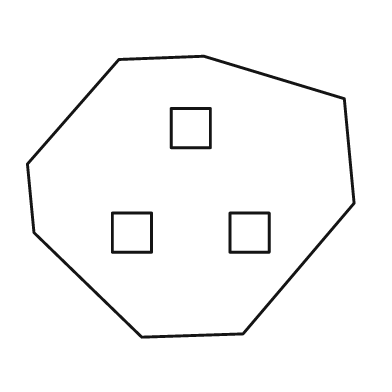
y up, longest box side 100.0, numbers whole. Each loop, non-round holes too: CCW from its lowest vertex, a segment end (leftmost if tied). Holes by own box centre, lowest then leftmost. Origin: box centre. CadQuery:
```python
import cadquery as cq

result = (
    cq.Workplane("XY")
    .moveTo(-15.0, -43.0)
    .lineTo(16.0, -42.0)
    .lineTo(50.0, -2.0)
    .lineTo(47.0, 30.0)
    .lineTo(4.0, 43.0)
    .lineTo(-22.0, 42.0)
    .lineTo(-50.0, 10.0)
    .lineTo(-48.0, -11.0)
    .close()
    .moveTo(-24.0, -17.0)
    .lineTo(-12.0, -17.0)
    .lineTo(-12.0, -5.0)
    .lineTo(-24.0, -5.0)
    .close()
    .moveTo(12.0, -17.0)
    .lineTo(24.0, -17.0)
    .lineTo(24.0, -5.0)
    .lineTo(12.0, -5.0)
    .close()
    .moveTo(-6.0, 15.0)
    .lineTo(6.0, 15.0)
    .lineTo(6.0, 27.0)
    .lineTo(-6.0, 27.0)
    .close()
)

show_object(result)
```